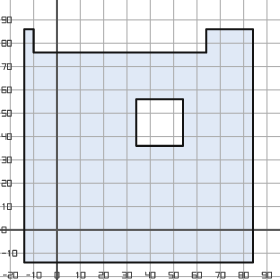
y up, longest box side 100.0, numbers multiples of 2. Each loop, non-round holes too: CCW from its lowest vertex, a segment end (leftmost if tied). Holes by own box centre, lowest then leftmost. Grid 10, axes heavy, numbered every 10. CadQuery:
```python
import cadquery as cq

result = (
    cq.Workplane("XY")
    .moveTo(-14.0, -14.0)
    .lineTo(84.0, -14.0)
    .lineTo(84.0, 86.0)
    .lineTo(64.0, 86.0)
    .lineTo(64.0, 76.0)
    .lineTo(-10.0, 76.0)
    .lineTo(-10.0, 86.0)
    .lineTo(-14.0, 86.0)
    .close()
    .moveTo(34.0, 36.0)
    .lineTo(54.0, 36.0)
    .lineTo(54.0, 56.0)
    .lineTo(34.0, 56.0)
    .close()
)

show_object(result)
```